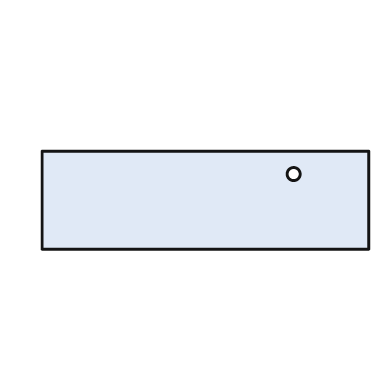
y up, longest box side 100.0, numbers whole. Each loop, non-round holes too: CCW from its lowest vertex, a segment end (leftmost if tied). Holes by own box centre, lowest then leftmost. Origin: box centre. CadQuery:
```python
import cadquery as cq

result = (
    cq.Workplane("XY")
    .moveTo(-50.0, -15.0)
    .lineTo(50.0, -15.0)
    .lineTo(50.0, 15.0)
    .lineTo(-50.0, 15.0)
    .close()
    .moveTo(27.0, 8.0)
    .circle(2.0)
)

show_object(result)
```